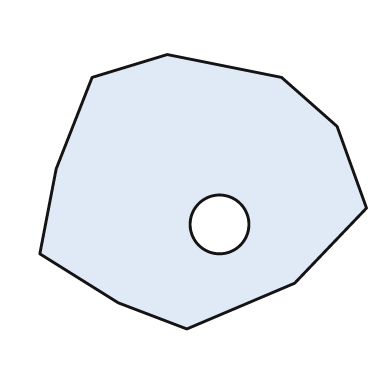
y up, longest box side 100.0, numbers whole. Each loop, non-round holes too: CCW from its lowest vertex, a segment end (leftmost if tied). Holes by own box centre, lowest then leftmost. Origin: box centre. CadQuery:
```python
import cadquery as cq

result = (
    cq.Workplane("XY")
    .moveTo(-5.0, -42.0)
    .lineTo(28.0, -28.0)
    .lineTo(50.0, -5.0)
    .lineTo(41.0, 20.0)
    .lineTo(24.0, 35.0)
    .lineTo(-11.0, 42.0)
    .lineTo(-34.0, 35.0)
    .lineTo(-45.0, 7.0)
    .lineTo(-50.0, -19.0)
    .lineTo(-26.0, -34.0)
    .close()
    .moveTo(5.0, -10.0)
    .circle(9.0)
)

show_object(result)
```